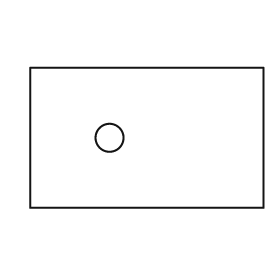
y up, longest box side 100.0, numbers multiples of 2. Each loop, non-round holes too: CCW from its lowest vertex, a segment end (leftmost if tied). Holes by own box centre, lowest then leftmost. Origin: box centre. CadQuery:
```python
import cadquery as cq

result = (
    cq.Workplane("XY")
    .moveTo(-50.0, -30.0)
    .lineTo(50.0, -30.0)
    .lineTo(50.0, 30.0)
    .lineTo(-50.0, 30.0)
    .close()
    .moveTo(-16.0, 0.0)
    .circle(6.0)
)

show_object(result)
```